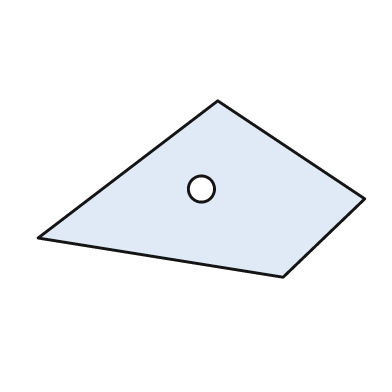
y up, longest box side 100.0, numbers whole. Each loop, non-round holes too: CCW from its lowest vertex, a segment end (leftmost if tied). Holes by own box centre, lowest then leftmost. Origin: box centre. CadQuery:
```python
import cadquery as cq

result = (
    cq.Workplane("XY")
    .moveTo(25.0, -27.0)
    .lineTo(50.0, -3.0)
    .lineTo(5.0, 27.0)
    .lineTo(-50.0, -15.0)
    .close()
    .moveTo(0.0, 0.0)
    .circle(4.0)
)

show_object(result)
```